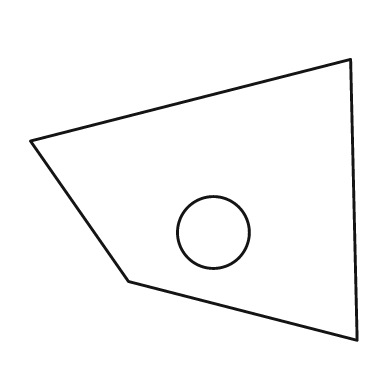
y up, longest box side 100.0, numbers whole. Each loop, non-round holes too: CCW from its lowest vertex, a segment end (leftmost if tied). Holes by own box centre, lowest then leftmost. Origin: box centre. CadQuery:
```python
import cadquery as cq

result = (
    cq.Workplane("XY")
    .moveTo(50.0, -43.0)
    .lineTo(48.0, 43.0)
    .lineTo(-50.0, 18.0)
    .lineTo(-20.0, -25.0)
    .close()
    .moveTo(6.0, -10.0)
    .circle(11.0)
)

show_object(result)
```